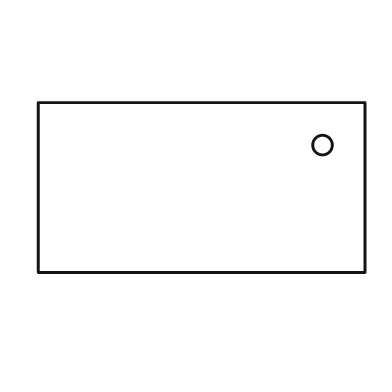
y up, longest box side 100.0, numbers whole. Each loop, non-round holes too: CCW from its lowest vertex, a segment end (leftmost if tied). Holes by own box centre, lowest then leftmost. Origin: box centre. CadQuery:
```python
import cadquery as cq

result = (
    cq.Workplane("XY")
    .moveTo(-50.0, -26.0)
    .lineTo(50.0, -26.0)
    .lineTo(50.0, 26.0)
    .lineTo(-50.0, 26.0)
    .close()
    .moveTo(37.0, 13.0)
    .circle(3.0)
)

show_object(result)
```